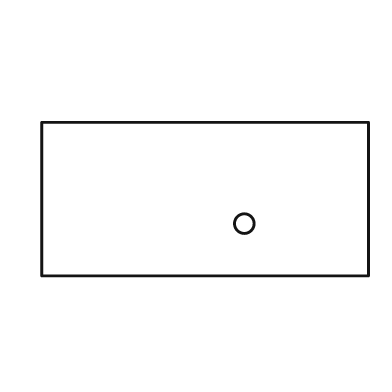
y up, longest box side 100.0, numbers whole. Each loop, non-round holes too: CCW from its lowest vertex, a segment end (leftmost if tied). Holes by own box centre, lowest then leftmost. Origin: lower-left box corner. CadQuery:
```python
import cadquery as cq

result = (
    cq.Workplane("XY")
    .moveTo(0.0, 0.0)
    .lineTo(100.0, 0.0)
    .lineTo(100.0, 47.0)
    .lineTo(0.0, 47.0)
    .close()
    .moveTo(62.0, 16.0)
    .circle(3.0)
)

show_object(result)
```